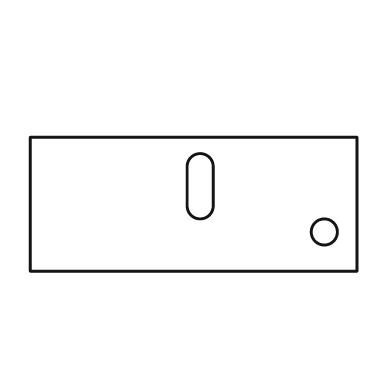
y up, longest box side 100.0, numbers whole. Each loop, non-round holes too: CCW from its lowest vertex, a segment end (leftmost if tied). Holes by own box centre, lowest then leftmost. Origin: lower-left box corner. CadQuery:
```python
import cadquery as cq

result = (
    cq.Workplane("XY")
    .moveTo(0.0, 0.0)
    .lineTo(100.0, 0.0)
    .lineTo(100.0, 41.0)
    .lineTo(0.0, 41.0)
    .close()
    .moveTo(90.0, 12.0)
    .circle(4.0)
    .moveTo(48.0, 20.0)
    .threePointArc((52.0, 16.0), (56.0, 20.0))
    .lineTo(56.0, 32.0)
    .threePointArc((52.0, 36.0), (48.0, 32.0))
    .close()
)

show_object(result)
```